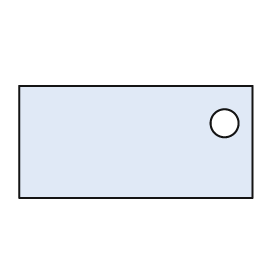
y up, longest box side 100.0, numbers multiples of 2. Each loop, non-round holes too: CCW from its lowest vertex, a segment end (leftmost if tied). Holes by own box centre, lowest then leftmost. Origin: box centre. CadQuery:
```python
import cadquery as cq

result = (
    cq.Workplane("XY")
    .moveTo(-50.0, -24.0)
    .lineTo(50.0, -24.0)
    .lineTo(50.0, 24.0)
    .lineTo(-50.0, 24.0)
    .close()
    .moveTo(38.0, 8.0)
    .circle(6.0)
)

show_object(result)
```